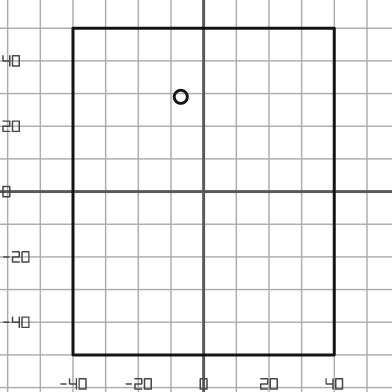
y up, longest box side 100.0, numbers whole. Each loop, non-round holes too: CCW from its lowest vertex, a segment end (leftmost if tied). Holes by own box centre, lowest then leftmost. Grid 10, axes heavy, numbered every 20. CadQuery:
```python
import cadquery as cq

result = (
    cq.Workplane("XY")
    .moveTo(-40.0, -50.0)
    .lineTo(40.0, -50.0)
    .lineTo(40.0, 50.0)
    .lineTo(-40.0, 50.0)
    .close()
    .moveTo(-7.0, 29.0)
    .circle(2.0)
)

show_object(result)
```